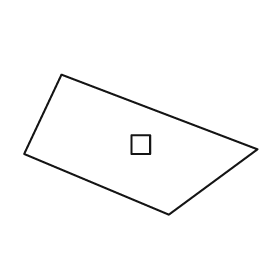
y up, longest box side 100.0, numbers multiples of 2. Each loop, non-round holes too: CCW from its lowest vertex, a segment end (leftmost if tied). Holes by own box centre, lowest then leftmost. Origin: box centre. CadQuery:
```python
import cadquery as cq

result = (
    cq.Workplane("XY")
    .moveTo(12.0, -30.0)
    .lineTo(50.0, -2.0)
    .lineTo(-34.0, 30.0)
    .lineTo(-50.0, -4.0)
    .close()
    .moveTo(-4.0, -4.0)
    .lineTo(4.0, -4.0)
    .lineTo(4.0, 4.0)
    .lineTo(-4.0, 4.0)
    .close()
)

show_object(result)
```